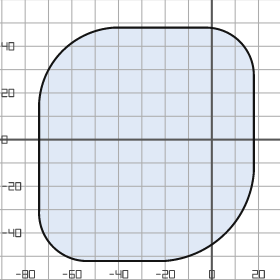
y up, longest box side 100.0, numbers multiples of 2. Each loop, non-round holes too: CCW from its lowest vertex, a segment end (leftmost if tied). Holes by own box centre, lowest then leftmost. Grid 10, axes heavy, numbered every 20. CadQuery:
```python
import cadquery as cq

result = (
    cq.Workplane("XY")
    .moveTo(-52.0, -52.0)
    .lineTo(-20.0, -52.0)
    .threePointArc((6.0, -40.0), (18.0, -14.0))
    .lineTo(18.0, 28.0)
    .threePointArc((12.0, 42.0), (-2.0, 48.0))
    .lineTo(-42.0, 48.0)
    .threePointArc((-64.0, 38.0), (-74.0, 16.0))
    .lineTo(-74.0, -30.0)
    .threePointArc((-68.0, -46.0), (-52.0, -52.0))
    .close()
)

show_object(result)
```